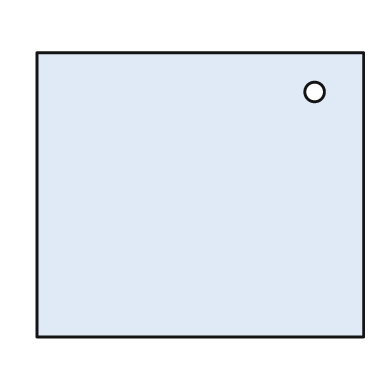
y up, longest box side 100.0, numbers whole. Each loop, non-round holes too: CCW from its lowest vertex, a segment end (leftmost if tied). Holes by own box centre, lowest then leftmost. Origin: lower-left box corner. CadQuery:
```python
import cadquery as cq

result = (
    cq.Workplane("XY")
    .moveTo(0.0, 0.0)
    .lineTo(100.0, 0.0)
    .lineTo(100.0, 87.0)
    .lineTo(0.0, 87.0)
    .close()
    .moveTo(85.0, 75.0)
    .circle(3.0)
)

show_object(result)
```